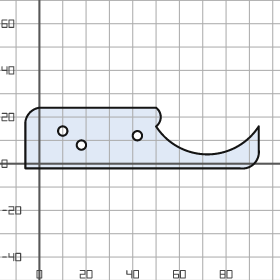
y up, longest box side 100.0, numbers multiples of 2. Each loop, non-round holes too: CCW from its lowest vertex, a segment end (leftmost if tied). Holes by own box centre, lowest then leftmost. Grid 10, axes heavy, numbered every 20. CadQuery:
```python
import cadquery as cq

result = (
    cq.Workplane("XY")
    .moveTo(-6.0, -2.0)
    .lineTo(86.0, -2.0)
    .threePointArc((92.0, 0.0), (94.0, 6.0))
    .lineTo(94.0, 16.0)
    .threePointArc((72.0, 4.0), (50.0, 16.0))
    .threePointArc((52.0, 20.0), (50.0, 24.0))
    .lineTo(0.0, 24.0)
    .threePointArc((-4.0, 22.0), (-6.0, 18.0))
    .close()
    .moveTo(18.0, 8.0)
    .circle(2.0)
    .moveTo(42.0, 12.0)
    .circle(2.0)
    .moveTo(10.0, 14.0)
    .circle(2.0)
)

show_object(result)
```